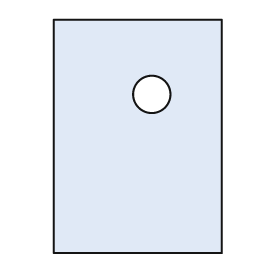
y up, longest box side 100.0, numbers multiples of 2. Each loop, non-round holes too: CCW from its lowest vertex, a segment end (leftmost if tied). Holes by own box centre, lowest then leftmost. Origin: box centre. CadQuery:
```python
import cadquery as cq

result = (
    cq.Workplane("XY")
    .moveTo(-36.0, -50.0)
    .lineTo(36.0, -50.0)
    .lineTo(36.0, 50.0)
    .lineTo(-36.0, 50.0)
    .close()
    .moveTo(6.0, 18.0)
    .circle(8.0)
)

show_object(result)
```